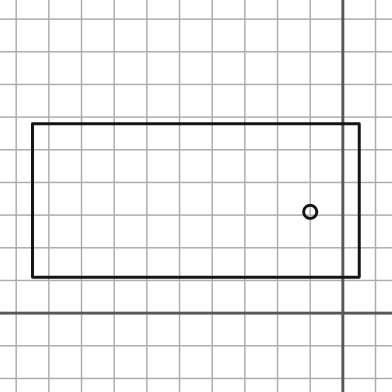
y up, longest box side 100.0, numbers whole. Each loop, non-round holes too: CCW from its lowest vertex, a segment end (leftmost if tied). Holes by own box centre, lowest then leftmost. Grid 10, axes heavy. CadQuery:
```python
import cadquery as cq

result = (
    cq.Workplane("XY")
    .moveTo(-95.0, 11.0)
    .lineTo(5.0, 11.0)
    .lineTo(5.0, 58.0)
    .lineTo(-95.0, 58.0)
    .close()
    .moveTo(-10.0, 31.0)
    .circle(2.0)
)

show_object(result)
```